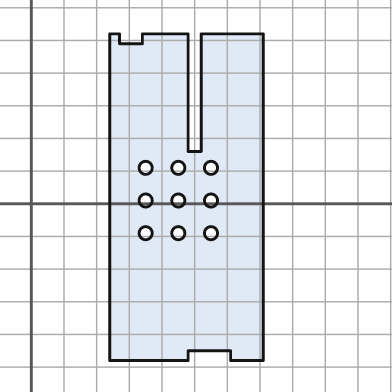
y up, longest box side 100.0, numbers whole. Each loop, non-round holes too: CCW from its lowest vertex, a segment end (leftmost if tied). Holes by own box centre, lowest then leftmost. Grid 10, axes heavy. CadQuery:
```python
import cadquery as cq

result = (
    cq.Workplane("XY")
    .moveTo(24.0, -48.0)
    .lineTo(48.0, -48.0)
    .lineTo(48.0, -45.0)
    .lineTo(61.0, -45.0)
    .lineTo(61.0, -48.0)
    .lineTo(71.0, -48.0)
    .lineTo(71.0, 52.0)
    .lineTo(52.0, 52.0)
    .lineTo(52.0, 16.0)
    .lineTo(48.0, 16.0)
    .lineTo(48.0, 52.0)
    .lineTo(34.0, 52.0)
    .lineTo(34.0, 49.0)
    .lineTo(27.0, 49.0)
    .lineTo(27.0, 52.0)
    .lineTo(24.0, 52.0)
    .close()
    .moveTo(35.0, -9.0)
    .circle(2.0)
    .moveTo(45.0, -9.0)
    .circle(2.0)
    .moveTo(55.0, -9.0)
    .circle(2.0)
    .moveTo(35.0, 1.0)
    .circle(2.0)
    .moveTo(45.0, 1.0)
    .circle(2.0)
    .moveTo(55.0, 1.0)
    .circle(2.0)
    .moveTo(35.0, 11.0)
    .circle(2.0)
    .moveTo(45.0, 11.0)
    .circle(2.0)
    .moveTo(55.0, 11.0)
    .circle(2.0)
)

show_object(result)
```